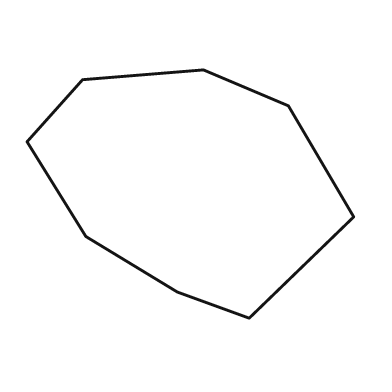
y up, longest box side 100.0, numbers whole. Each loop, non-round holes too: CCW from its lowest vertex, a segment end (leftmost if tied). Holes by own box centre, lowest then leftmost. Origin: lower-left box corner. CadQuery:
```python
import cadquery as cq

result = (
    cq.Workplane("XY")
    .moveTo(68.0, 0.0)
    .lineTo(100.0, 31.0)
    .lineTo(80.0, 65.0)
    .lineTo(54.0, 76.0)
    .lineTo(17.0, 73.0)
    .lineTo(0.0, 54.0)
    .lineTo(18.0, 25.0)
    .lineTo(46.0, 8.0)
    .close()
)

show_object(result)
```